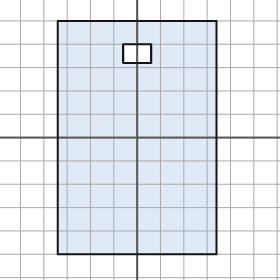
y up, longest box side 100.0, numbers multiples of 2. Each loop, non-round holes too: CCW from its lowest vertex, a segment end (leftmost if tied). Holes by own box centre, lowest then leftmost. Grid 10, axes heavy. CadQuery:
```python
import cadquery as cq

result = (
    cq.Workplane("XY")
    .moveTo(-34.0, -50.0)
    .lineTo(34.0, -50.0)
    .lineTo(34.0, 50.0)
    .lineTo(-34.0, 50.0)
    .close()
    .moveTo(-6.0, 32.0)
    .lineTo(6.0, 32.0)
    .lineTo(6.0, 40.0)
    .lineTo(-6.0, 40.0)
    .close()
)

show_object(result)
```